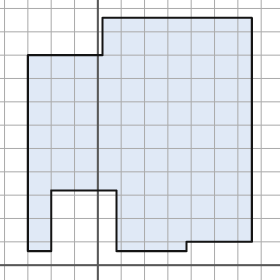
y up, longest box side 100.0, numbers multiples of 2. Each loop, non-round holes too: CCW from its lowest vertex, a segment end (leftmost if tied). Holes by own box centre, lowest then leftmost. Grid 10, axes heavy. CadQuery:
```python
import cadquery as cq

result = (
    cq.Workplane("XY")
    .moveTo(-30.0, 6.0)
    .lineTo(-20.0, 6.0)
    .lineTo(-20.0, 32.0)
    .lineTo(8.0, 32.0)
    .lineTo(8.0, 6.0)
    .lineTo(38.0, 6.0)
    .lineTo(38.0, 10.0)
    .lineTo(66.0, 10.0)
    .lineTo(66.0, 106.0)
    .lineTo(2.0, 106.0)
    .lineTo(2.0, 90.0)
    .lineTo(-30.0, 90.0)
    .close()
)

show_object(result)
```